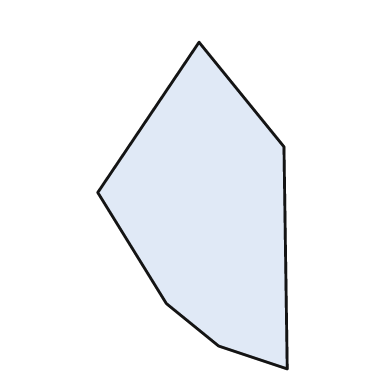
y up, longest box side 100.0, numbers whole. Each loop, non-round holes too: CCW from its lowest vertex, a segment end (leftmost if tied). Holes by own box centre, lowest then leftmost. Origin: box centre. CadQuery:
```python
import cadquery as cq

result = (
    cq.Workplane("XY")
    .moveTo(29.0, -50.0)
    .lineTo(28.0, 18.0)
    .lineTo(2.0, 50.0)
    .lineTo(-29.0, 4.0)
    .lineTo(-8.0, -30.0)
    .lineTo(8.0, -43.0)
    .close()
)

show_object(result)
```